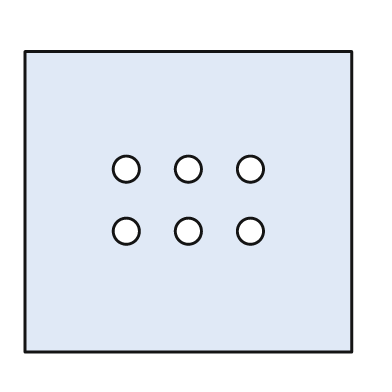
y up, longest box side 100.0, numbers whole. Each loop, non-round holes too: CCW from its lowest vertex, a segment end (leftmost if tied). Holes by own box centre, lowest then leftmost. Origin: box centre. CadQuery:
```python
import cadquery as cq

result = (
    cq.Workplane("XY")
    .moveTo(-50.0, -46.0)
    .lineTo(50.0, -46.0)
    .lineTo(50.0, 46.0)
    .lineTo(-50.0, 46.0)
    .close()
    .moveTo(-19.0, -9.0)
    .circle(4.0)
    .moveTo(0.0, -9.0)
    .circle(4.0)
    .moveTo(19.0, -9.0)
    .circle(4.0)
    .moveTo(-19.0, 10.0)
    .circle(4.0)
    .moveTo(0.0, 10.0)
    .circle(4.0)
    .moveTo(19.0, 10.0)
    .circle(4.0)
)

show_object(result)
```